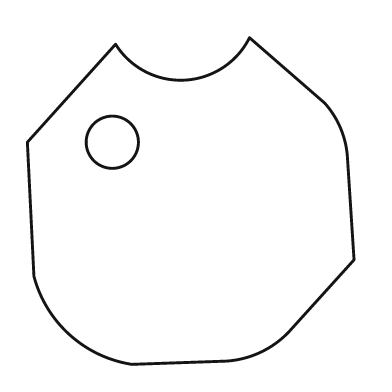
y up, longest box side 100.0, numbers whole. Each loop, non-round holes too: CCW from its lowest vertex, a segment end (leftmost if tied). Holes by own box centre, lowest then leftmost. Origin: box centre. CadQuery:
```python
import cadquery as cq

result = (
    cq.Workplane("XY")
    .moveTo(-18.0, -50.0)
    .lineTo(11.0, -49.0)
    .threePointArc((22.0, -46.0), (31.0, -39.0))
    .lineTo(50.0, -18.0)
    .lineTo(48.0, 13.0)
    .threePointArc((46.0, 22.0), (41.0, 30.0))
    .lineTo(18.0, 50.0)
    .threePointArc((-2.0, 37.0), (-23.0, 48.0))
    .lineTo(-50.0, 18.0)
    .lineTo(-48.0, -23.0)
    .threePointArc((-37.0, -41.0), (-18.0, -50.0))
    .close()
    .moveTo(-24.0, 18.0)
    .circle(8.0)
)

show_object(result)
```